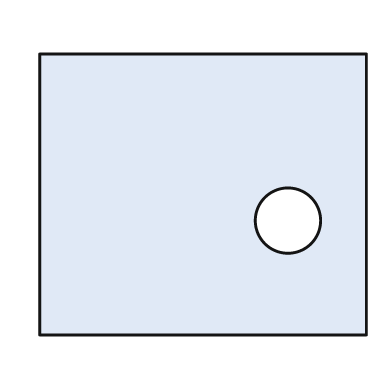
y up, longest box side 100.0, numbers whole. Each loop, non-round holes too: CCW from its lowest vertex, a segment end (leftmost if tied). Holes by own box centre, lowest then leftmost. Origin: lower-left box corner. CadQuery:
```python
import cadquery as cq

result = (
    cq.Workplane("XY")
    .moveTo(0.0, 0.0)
    .lineTo(100.0, 0.0)
    .lineTo(100.0, 86.0)
    .lineTo(0.0, 86.0)
    .close()
    .moveTo(76.0, 35.0)
    .circle(10.0)
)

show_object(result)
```